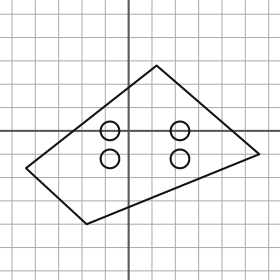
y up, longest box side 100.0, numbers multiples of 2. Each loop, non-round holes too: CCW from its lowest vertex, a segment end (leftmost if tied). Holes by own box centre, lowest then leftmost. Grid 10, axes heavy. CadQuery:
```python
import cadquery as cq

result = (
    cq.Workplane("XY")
    .moveTo(-18.0, -40.0)
    .lineTo(56.0, -10.0)
    .lineTo(12.0, 28.0)
    .lineTo(-44.0, -16.0)
    .close()
    .moveTo(-8.0, -12.0)
    .circle(4.0)
    .moveTo(22.0, -12.0)
    .circle(4.0)
    .moveTo(-8.0, 0.0)
    .circle(4.0)
    .moveTo(22.0, 0.0)
    .circle(4.0)
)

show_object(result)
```